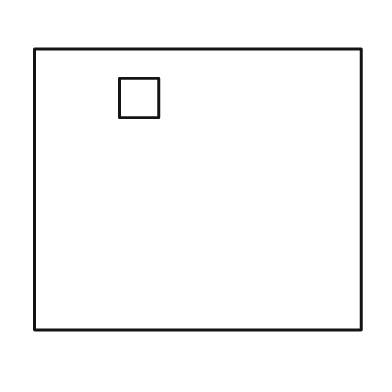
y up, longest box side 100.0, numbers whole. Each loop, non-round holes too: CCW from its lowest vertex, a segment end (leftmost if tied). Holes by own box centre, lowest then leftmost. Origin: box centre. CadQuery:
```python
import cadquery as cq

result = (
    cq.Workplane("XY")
    .moveTo(-50.0, -43.0)
    .lineTo(50.0, -43.0)
    .lineTo(50.0, 43.0)
    .lineTo(-50.0, 43.0)
    .close()
    .moveTo(-24.0, 22.0)
    .lineTo(-12.0, 22.0)
    .lineTo(-12.0, 34.0)
    .lineTo(-24.0, 34.0)
    .close()
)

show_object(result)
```